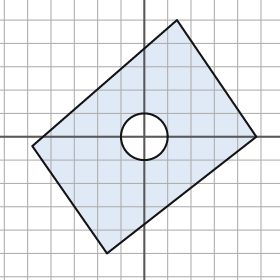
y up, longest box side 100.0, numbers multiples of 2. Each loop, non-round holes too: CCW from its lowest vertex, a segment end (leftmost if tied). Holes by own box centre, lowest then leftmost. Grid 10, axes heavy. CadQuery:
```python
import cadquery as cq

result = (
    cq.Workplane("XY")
    .moveTo(-16.0, -50.0)
    .lineTo(48.0, 0.0)
    .lineTo(14.0, 50.0)
    .lineTo(-48.0, -4.0)
    .close()
    .moveTo(0.0, 0.0)
    .circle(10.0)
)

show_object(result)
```